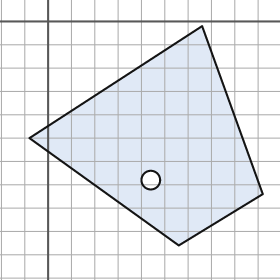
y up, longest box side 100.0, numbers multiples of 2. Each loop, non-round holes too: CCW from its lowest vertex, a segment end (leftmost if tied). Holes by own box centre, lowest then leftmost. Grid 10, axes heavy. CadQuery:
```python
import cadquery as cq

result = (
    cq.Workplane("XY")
    .moveTo(56.0, -96.0)
    .lineTo(92.0, -74.0)
    .lineTo(66.0, -2.0)
    .lineTo(-8.0, -50.0)
    .close()
    .moveTo(44.0, -68.0)
    .circle(4.0)
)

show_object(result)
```